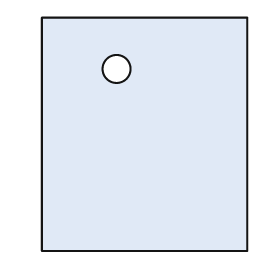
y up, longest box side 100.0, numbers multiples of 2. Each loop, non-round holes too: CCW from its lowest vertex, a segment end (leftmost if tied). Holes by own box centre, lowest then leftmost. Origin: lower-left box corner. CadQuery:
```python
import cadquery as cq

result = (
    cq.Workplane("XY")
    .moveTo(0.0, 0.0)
    .lineTo(88.0, 0.0)
    .lineTo(88.0, 100.0)
    .lineTo(0.0, 100.0)
    .close()
    .moveTo(32.0, 78.0)
    .circle(6.0)
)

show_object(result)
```